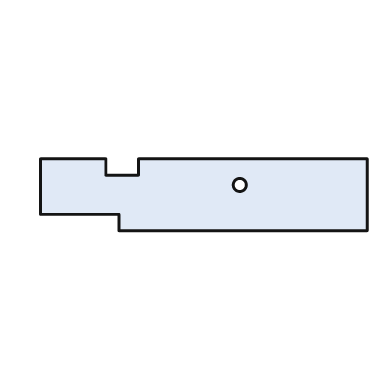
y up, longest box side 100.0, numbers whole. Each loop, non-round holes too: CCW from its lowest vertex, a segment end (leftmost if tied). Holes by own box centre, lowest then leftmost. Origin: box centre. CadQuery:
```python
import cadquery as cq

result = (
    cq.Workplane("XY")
    .moveTo(-26.0, -11.0)
    .lineTo(50.0, -11.0)
    .lineTo(50.0, 11.0)
    .lineTo(-20.0, 11.0)
    .lineTo(-20.0, 6.0)
    .lineTo(-30.0, 6.0)
    .lineTo(-30.0, 11.0)
    .lineTo(-50.0, 11.0)
    .lineTo(-50.0, -6.0)
    .lineTo(-26.0, -6.0)
    .close()
    .moveTo(11.0, 3.0)
    .circle(2.0)
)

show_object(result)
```